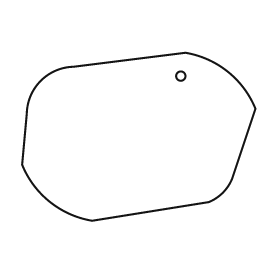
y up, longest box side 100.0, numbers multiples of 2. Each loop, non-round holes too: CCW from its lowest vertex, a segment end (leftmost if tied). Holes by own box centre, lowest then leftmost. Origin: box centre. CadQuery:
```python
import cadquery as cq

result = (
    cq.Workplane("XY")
    .moveTo(-20.0, -36.0)
    .lineTo(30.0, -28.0)
    .threePointArc((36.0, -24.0), (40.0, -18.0))
    .lineTo(50.0, 12.0)
    .threePointArc((38.0, 28.0), (20.0, 36.0))
    .lineTo(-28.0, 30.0)
    .threePointArc((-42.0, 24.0), (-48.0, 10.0))
    .lineTo(-50.0, -12.0)
    .threePointArc((-38.0, -28.0), (-20.0, -36.0))
    .close()
    .moveTo(18.0, 26.0)
    .circle(2.0)
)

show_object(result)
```